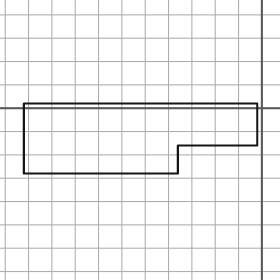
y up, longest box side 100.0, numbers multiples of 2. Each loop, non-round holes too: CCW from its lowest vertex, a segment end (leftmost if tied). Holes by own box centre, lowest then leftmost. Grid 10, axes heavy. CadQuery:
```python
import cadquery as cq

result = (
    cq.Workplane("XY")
    .moveTo(-102.0, -28.0)
    .lineTo(-36.0, -28.0)
    .lineTo(-36.0, -16.0)
    .lineTo(-2.0, -16.0)
    .lineTo(-2.0, 2.0)
    .lineTo(-102.0, 2.0)
    .close()
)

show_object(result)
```